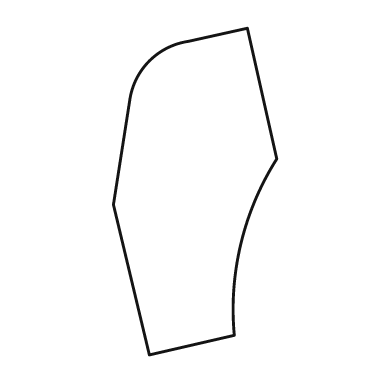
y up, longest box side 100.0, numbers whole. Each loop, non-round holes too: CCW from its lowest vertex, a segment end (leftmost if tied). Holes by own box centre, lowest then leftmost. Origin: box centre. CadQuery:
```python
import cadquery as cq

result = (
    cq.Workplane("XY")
    .moveTo(-14.0, -50.0)
    .lineTo(12.0, -44.0)
    .threePointArc((14.0, -16.0), (25.0, 10.0))
    .lineTo(16.0, 50.0)
    .lineTo(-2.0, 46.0)
    .threePointArc((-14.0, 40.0), (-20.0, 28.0))
    .lineTo(-25.0, -4.0)
    .close()
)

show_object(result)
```